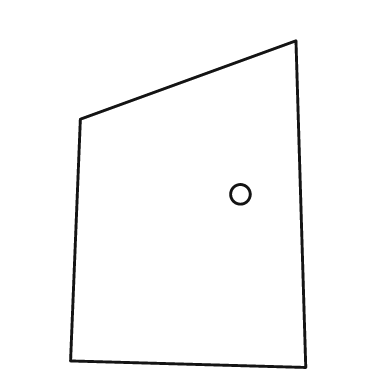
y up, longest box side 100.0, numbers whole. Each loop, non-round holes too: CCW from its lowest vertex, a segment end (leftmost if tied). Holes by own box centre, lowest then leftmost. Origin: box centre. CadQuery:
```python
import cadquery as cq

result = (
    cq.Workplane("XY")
    .moveTo(36.0, -50.0)
    .lineTo(33.0, 50.0)
    .lineTo(-33.0, 26.0)
    .lineTo(-36.0, -48.0)
    .close()
    .moveTo(16.0, 3.0)
    .circle(3.0)
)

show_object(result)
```